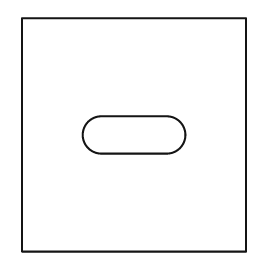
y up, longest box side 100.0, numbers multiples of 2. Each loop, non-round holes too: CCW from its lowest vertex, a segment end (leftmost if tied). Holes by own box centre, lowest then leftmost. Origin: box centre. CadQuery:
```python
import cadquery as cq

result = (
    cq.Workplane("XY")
    .moveTo(-48.0, -50.0)
    .lineTo(48.0, -50.0)
    .lineTo(48.0, 50.0)
    .lineTo(-48.0, 50.0)
    .close()
    .moveTo(-14.0, -8.0)
    .lineTo(14.0, -8.0)
    .threePointArc((22.0, 0.0), (14.0, 8.0))
    .lineTo(-14.0, 8.0)
    .threePointArc((-22.0, 0.0), (-14.0, -8.0))
    .close()
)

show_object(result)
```